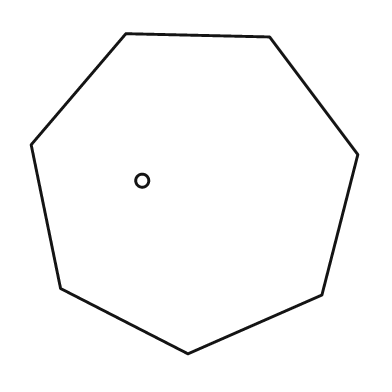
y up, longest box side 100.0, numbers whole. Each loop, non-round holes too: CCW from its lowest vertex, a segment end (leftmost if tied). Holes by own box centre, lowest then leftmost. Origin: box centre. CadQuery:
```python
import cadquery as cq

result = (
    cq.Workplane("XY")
    .moveTo(-2.0, -49.0)
    .lineTo(39.0, -31.0)
    .lineTo(50.0, 12.0)
    .lineTo(23.0, 48.0)
    .lineTo(-21.0, 49.0)
    .lineTo(-50.0, 15.0)
    .lineTo(-41.0, -29.0)
    .close()
    .moveTo(-16.0, 4.0)
    .circle(2.0)
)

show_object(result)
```